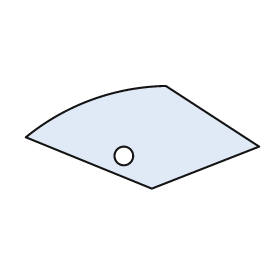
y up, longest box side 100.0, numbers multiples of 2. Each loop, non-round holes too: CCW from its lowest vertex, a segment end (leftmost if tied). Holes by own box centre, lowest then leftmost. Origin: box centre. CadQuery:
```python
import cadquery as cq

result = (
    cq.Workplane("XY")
    .moveTo(4.0, -22.0)
    .lineTo(50.0, -4.0)
    .lineTo(10.0, 22.0)
    .threePointArc((-22.0, 16.0), (-50.0, 0.0))
    .close()
    .moveTo(-8.0, -8.0)
    .circle(4.0)
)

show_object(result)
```